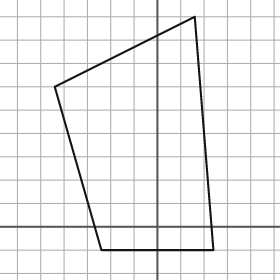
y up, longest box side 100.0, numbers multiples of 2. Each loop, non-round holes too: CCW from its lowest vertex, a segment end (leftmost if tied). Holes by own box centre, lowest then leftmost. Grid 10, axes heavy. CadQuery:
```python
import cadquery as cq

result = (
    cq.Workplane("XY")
    .moveTo(-24.0, -10.0)
    .lineTo(24.0, -10.0)
    .lineTo(16.0, 90.0)
    .lineTo(-44.0, 60.0)
    .close()
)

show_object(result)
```